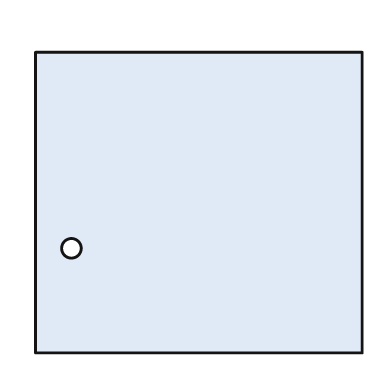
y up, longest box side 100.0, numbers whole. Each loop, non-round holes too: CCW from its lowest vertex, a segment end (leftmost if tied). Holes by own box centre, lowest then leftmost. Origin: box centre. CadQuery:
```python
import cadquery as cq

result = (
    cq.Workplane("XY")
    .moveTo(-50.0, -46.0)
    .lineTo(50.0, -46.0)
    .lineTo(50.0, 46.0)
    .lineTo(-50.0, 46.0)
    .close()
    .moveTo(-39.0, -14.0)
    .circle(3.0)
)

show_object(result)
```